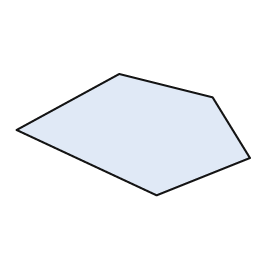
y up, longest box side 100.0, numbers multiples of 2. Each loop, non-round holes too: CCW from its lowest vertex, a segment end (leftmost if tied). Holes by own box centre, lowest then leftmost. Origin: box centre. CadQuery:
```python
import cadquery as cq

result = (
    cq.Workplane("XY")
    .moveTo(10.0, -26.0)
    .lineTo(50.0, -10.0)
    .lineTo(34.0, 16.0)
    .lineTo(-6.0, 26.0)
    .lineTo(-50.0, 2.0)
    .close()
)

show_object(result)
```